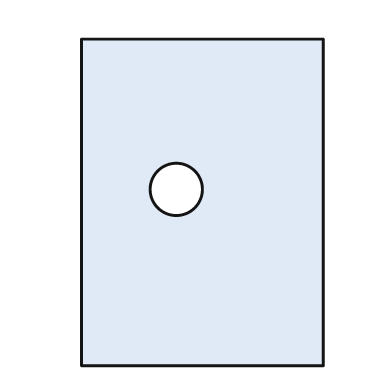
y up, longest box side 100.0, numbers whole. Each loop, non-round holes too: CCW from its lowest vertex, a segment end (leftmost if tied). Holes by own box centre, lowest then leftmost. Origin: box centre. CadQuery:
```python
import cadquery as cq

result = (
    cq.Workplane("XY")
    .moveTo(-37.0, -50.0)
    .lineTo(37.0, -50.0)
    .lineTo(37.0, 50.0)
    .lineTo(-37.0, 50.0)
    .close()
    .moveTo(-8.0, 4.0)
    .circle(8.0)
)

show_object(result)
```